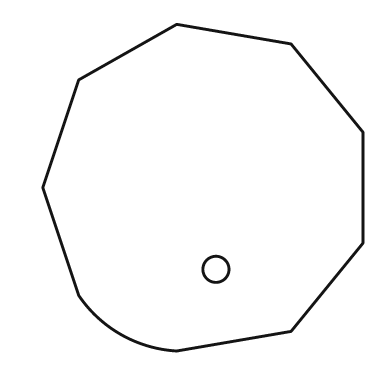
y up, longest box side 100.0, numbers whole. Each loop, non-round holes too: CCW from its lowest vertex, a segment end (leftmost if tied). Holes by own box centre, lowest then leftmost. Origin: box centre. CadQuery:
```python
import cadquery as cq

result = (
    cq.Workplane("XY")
    .moveTo(-8.0, -50.0)
    .lineTo(27.0, -44.0)
    .lineTo(49.0, -17.0)
    .lineTo(49.0, 17.0)
    .lineTo(27.0, 44.0)
    .lineTo(-8.0, 50.0)
    .lineTo(-38.0, 33.0)
    .lineTo(-49.0, 0.0)
    .lineTo(-38.0, -33.0)
    .threePointArc((-25.0, -45.0), (-8.0, -50.0))
    .close()
    .moveTo(4.0, -25.0)
    .circle(4.0)
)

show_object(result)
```